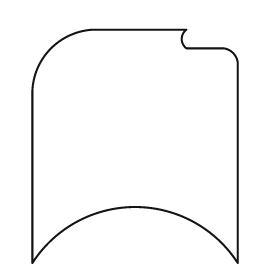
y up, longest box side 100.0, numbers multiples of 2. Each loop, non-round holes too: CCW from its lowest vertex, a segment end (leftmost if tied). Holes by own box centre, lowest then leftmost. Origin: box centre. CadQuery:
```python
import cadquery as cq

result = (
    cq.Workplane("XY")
    .moveTo(-44.0, -50.0)
    .threePointArc((0.0, -26.0), (44.0, -50.0))
    .lineTo(44.0, 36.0)
    .threePointArc((42.0, 40.0), (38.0, 42.0))
    .lineTo(22.0, 42.0)
    .threePointArc((20.0, 46.0), (22.0, 50.0))
    .lineTo(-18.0, 50.0)
    .threePointArc((-36.0, 42.0), (-44.0, 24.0))
    .close()
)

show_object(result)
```